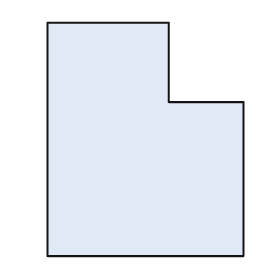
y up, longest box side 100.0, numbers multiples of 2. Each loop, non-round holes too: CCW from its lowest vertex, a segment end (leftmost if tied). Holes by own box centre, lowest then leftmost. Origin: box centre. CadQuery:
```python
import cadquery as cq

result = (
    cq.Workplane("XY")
    .moveTo(-42.0, -50.0)
    .lineTo(42.0, -50.0)
    .lineTo(42.0, 16.0)
    .lineTo(10.0, 16.0)
    .lineTo(10.0, 50.0)
    .lineTo(-42.0, 50.0)
    .close()
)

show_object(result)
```